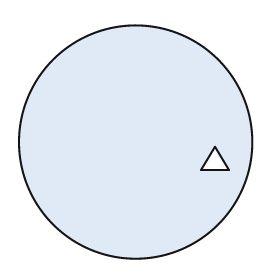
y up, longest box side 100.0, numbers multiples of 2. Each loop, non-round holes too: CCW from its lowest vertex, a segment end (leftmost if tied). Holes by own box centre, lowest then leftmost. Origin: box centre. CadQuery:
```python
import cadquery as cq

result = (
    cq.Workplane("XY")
    .moveTo(0.0, 0.0)
    .circle(50.0)
    .moveTo(28.0, -12.0)
    .lineTo(40.0, -12.0)
    .lineTo(34.0, -2.0)
    .close()
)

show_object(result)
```